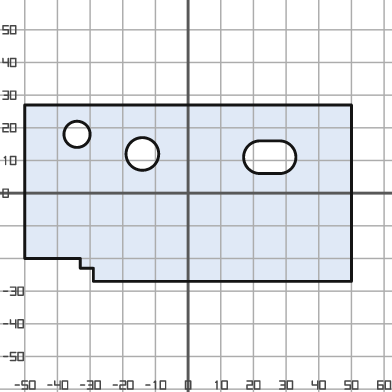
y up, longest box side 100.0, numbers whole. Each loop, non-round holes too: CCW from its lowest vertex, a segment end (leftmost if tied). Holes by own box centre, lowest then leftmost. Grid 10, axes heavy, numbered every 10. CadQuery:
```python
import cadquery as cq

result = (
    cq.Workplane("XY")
    .moveTo(-29.0, -27.0)
    .lineTo(50.0, -27.0)
    .lineTo(50.0, 27.0)
    .lineTo(-50.0, 27.0)
    .lineTo(-50.0, -20.0)
    .lineTo(-33.0, -20.0)
    .lineTo(-33.0, -23.0)
    .lineTo(-29.0, -23.0)
    .close()
    .moveTo(22.0, 6.0)
    .lineTo(28.0, 6.0)
    .threePointArc((33.0, 11.0), (28.0, 16.0))
    .lineTo(22.0, 16.0)
    .threePointArc((17.0, 11.0), (22.0, 6.0))
    .close()
    .moveTo(-14.0, 12.0)
    .circle(5.0)
    .moveTo(-34.0, 18.0)
    .circle(4.0)
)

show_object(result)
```